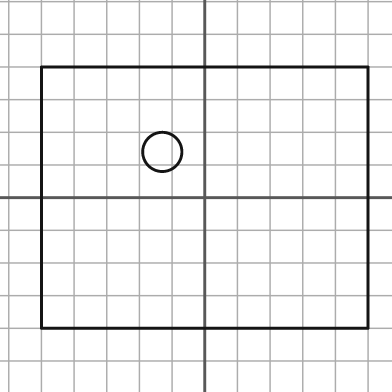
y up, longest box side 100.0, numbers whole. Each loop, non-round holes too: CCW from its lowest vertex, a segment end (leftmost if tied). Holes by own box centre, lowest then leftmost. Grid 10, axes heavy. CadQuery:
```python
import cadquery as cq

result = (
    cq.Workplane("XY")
    .moveTo(-50.0, -40.0)
    .lineTo(50.0, -40.0)
    .lineTo(50.0, 40.0)
    .lineTo(-50.0, 40.0)
    .close()
    .moveTo(-13.0, 14.0)
    .circle(6.0)
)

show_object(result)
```